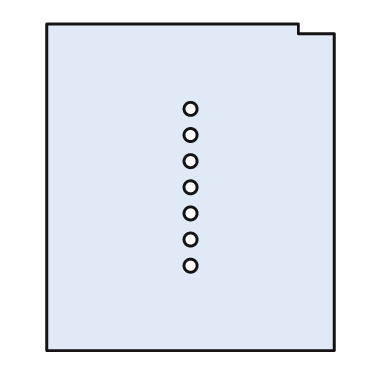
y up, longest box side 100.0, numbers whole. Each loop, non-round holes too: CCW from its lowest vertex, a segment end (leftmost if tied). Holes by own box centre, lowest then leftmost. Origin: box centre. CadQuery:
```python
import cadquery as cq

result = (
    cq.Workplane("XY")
    .moveTo(-44.0, -50.0)
    .lineTo(44.0, -50.0)
    .lineTo(44.0, 47.0)
    .lineTo(33.0, 47.0)
    .lineTo(33.0, 50.0)
    .lineTo(-44.0, 50.0)
    .close()
    .moveTo(0.0, -24.0)
    .circle(2.0)
    .moveTo(0.0, -16.0)
    .circle(2.0)
    .moveTo(0.0, -8.0)
    .circle(2.0)
    .moveTo(0.0, 0.0)
    .circle(2.0)
    .moveTo(0.0, 8.0)
    .circle(2.0)
    .moveTo(0.0, 16.0)
    .circle(2.0)
    .moveTo(0.0, 24.0)
    .circle(2.0)
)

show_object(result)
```